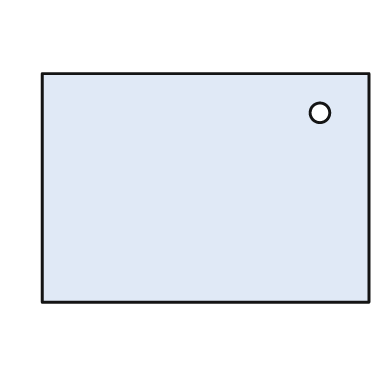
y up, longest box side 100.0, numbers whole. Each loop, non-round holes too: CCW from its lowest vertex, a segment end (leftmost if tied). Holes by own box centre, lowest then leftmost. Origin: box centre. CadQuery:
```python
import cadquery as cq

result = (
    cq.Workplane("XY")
    .moveTo(-50.0, -35.0)
    .lineTo(50.0, -35.0)
    .lineTo(50.0, 35.0)
    .lineTo(-50.0, 35.0)
    .close()
    .moveTo(35.0, 23.0)
    .circle(3.0)
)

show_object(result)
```